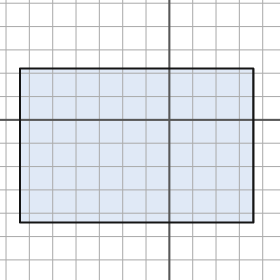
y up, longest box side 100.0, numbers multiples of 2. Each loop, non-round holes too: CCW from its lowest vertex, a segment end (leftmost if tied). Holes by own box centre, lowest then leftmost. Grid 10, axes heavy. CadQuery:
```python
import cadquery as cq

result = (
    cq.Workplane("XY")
    .moveTo(-64.0, -44.0)
    .lineTo(36.0, -44.0)
    .lineTo(36.0, 22.0)
    .lineTo(-64.0, 22.0)
    .close()
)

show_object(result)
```